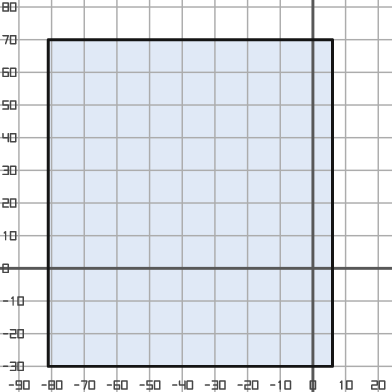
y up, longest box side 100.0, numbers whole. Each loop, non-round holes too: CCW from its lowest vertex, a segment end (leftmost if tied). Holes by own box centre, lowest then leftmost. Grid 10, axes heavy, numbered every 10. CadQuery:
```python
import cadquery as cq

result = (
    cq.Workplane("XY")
    .moveTo(-81.0, -30.0)
    .lineTo(6.0, -30.0)
    .lineTo(6.0, 70.0)
    .lineTo(-81.0, 70.0)
    .close()
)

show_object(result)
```